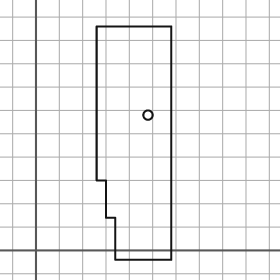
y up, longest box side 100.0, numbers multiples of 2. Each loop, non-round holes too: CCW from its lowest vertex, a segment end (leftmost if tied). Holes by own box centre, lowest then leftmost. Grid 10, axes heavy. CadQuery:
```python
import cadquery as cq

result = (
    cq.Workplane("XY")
    .moveTo(34.0, -4.0)
    .lineTo(58.0, -4.0)
    .lineTo(58.0, 96.0)
    .lineTo(26.0, 96.0)
    .lineTo(26.0, 30.0)
    .lineTo(30.0, 30.0)
    .lineTo(30.0, 14.0)
    .lineTo(34.0, 14.0)
    .close()
    .moveTo(48.0, 58.0)
    .circle(2.0)
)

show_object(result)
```